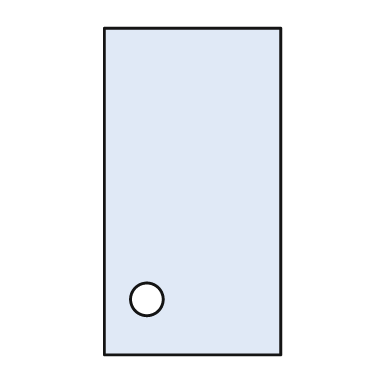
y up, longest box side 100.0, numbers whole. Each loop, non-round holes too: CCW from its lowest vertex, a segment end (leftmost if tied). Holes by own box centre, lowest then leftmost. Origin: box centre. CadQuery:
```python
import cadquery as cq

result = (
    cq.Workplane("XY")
    .moveTo(-27.0, -50.0)
    .lineTo(27.0, -50.0)
    .lineTo(27.0, 50.0)
    .lineTo(-27.0, 50.0)
    .close()
    .moveTo(-14.0, -33.0)
    .circle(5.0)
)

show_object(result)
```